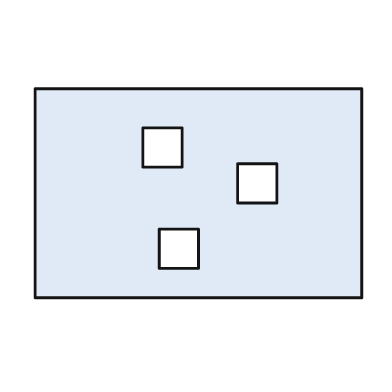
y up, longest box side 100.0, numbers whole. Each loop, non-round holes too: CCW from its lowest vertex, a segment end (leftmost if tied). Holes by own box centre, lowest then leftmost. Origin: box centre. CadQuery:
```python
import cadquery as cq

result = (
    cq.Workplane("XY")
    .moveTo(-50.0, -32.0)
    .lineTo(50.0, -32.0)
    .lineTo(50.0, 32.0)
    .lineTo(-50.0, 32.0)
    .close()
    .moveTo(-12.0, -23.0)
    .lineTo(0.0, -23.0)
    .lineTo(0.0, -11.0)
    .lineTo(-12.0, -11.0)
    .close()
    .moveTo(12.0, -3.0)
    .lineTo(24.0, -3.0)
    .lineTo(24.0, 9.0)
    .lineTo(12.0, 9.0)
    .close()
    .moveTo(-17.0, 8.0)
    .lineTo(-5.0, 8.0)
    .lineTo(-5.0, 20.0)
    .lineTo(-17.0, 20.0)
    .close()
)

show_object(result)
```